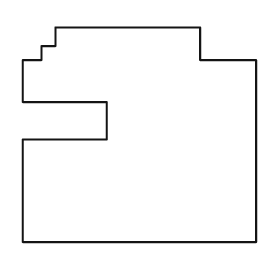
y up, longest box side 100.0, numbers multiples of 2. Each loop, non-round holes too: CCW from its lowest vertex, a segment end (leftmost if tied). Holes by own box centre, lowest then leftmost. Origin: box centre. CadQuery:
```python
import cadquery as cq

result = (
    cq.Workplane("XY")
    .moveTo(-50.0, -46.0)
    .lineTo(50.0, -46.0)
    .lineTo(50.0, 32.0)
    .lineTo(26.0, 32.0)
    .lineTo(26.0, 46.0)
    .lineTo(-36.0, 46.0)
    .lineTo(-36.0, 38.0)
    .lineTo(-42.0, 38.0)
    .lineTo(-42.0, 32.0)
    .lineTo(-50.0, 32.0)
    .lineTo(-50.0, 14.0)
    .lineTo(-14.0, 14.0)
    .lineTo(-14.0, -2.0)
    .lineTo(-50.0, -2.0)
    .close()
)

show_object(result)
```